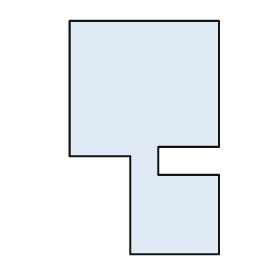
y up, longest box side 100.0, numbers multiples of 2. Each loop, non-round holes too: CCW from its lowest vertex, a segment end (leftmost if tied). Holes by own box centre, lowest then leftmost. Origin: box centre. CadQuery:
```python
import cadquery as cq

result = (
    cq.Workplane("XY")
    .moveTo(-6.0, -50.0)
    .lineTo(32.0, -50.0)
    .lineTo(32.0, -16.0)
    .lineTo(6.0, -16.0)
    .lineTo(6.0, -4.0)
    .lineTo(32.0, -4.0)
    .lineTo(32.0, 50.0)
    .lineTo(-32.0, 50.0)
    .lineTo(-32.0, -8.0)
    .lineTo(-6.0, -8.0)
    .close()
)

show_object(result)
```